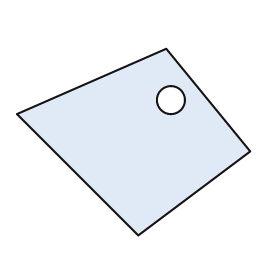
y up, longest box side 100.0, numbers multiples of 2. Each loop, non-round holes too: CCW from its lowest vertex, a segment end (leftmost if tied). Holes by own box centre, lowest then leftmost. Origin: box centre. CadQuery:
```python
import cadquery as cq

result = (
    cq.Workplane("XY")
    .moveTo(2.0, -40.0)
    .lineTo(50.0, -4.0)
    .lineTo(14.0, 40.0)
    .lineTo(-50.0, 12.0)
    .close()
    .moveTo(16.0, 18.0)
    .circle(6.0)
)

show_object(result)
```